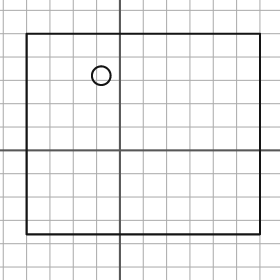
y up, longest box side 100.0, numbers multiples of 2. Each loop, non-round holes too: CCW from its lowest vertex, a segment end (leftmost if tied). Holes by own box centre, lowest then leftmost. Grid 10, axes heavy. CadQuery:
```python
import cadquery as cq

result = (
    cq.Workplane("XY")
    .moveTo(-40.0, -36.0)
    .lineTo(60.0, -36.0)
    .lineTo(60.0, 50.0)
    .lineTo(-40.0, 50.0)
    .close()
    .moveTo(-8.0, 32.0)
    .circle(4.0)
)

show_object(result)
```